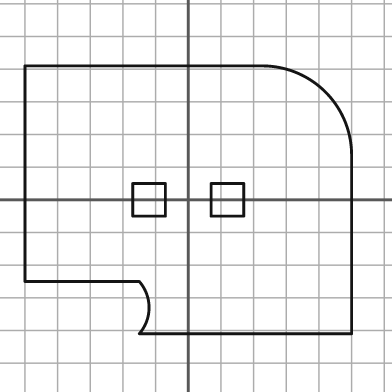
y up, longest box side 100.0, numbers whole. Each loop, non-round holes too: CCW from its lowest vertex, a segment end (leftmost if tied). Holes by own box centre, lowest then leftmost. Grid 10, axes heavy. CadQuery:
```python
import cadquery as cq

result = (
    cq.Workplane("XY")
    .moveTo(-15.0, -41.0)
    .lineTo(50.0, -41.0)
    .lineTo(50.0, 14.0)
    .threePointArc((42.0, 33.0), (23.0, 41.0))
    .lineTo(-50.0, 41.0)
    .lineTo(-50.0, -25.0)
    .lineTo(-15.0, -25.0)
    .threePointArc((-12.0, -33.0), (-15.0, -41.0))
    .close()
    .moveTo(-17.0, -5.0)
    .lineTo(-7.0, -5.0)
    .lineTo(-7.0, 5.0)
    .lineTo(-17.0, 5.0)
    .close()
    .moveTo(7.0, -5.0)
    .lineTo(17.0, -5.0)
    .lineTo(17.0, 5.0)
    .lineTo(7.0, 5.0)
    .close()
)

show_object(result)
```